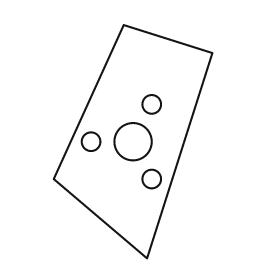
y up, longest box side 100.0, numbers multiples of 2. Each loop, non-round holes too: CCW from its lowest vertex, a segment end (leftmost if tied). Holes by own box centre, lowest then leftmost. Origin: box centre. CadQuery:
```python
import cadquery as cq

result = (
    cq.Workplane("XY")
    .moveTo(6.0, -50.0)
    .lineTo(34.0, 38.0)
    .lineTo(-4.0, 50.0)
    .lineTo(-34.0, -16.0)
    .close()
    .moveTo(8.0, -16.0)
    .circle(4.0)
    .moveTo(-18.0, 0.0)
    .circle(4.0)
    .moveTo(0.0, 0.0)
    .circle(8.0)
    .moveTo(8.0, 16.0)
    .circle(4.0)
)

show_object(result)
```